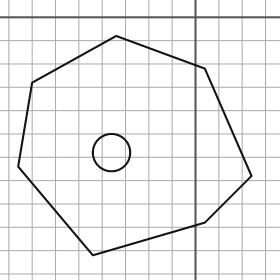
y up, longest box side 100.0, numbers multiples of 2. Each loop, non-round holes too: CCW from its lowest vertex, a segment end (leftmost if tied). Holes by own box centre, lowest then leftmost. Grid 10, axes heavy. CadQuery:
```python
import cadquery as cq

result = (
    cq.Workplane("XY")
    .moveTo(-44.0, -102.0)
    .lineTo(4.0, -88.0)
    .lineTo(24.0, -68.0)
    .lineTo(4.0, -22.0)
    .lineTo(-34.0, -8.0)
    .lineTo(-70.0, -28.0)
    .lineTo(-76.0, -64.0)
    .close()
    .moveTo(-36.0, -58.0)
    .circle(8.0)
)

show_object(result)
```